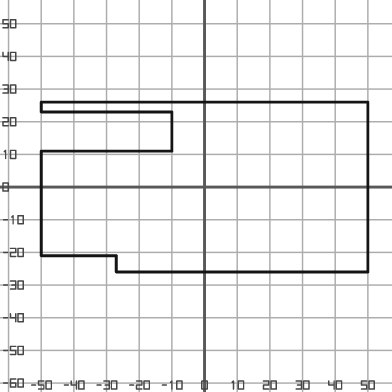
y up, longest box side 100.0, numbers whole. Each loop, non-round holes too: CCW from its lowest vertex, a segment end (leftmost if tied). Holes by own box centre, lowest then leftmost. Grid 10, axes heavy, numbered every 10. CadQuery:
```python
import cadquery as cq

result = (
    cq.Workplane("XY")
    .moveTo(-27.0, -26.0)
    .lineTo(50.0, -26.0)
    .lineTo(50.0, 26.0)
    .lineTo(-50.0, 26.0)
    .lineTo(-50.0, 23.0)
    .lineTo(-10.0, 23.0)
    .lineTo(-10.0, 11.0)
    .lineTo(-50.0, 11.0)
    .lineTo(-50.0, -21.0)
    .lineTo(-27.0, -21.0)
    .close()
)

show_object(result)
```